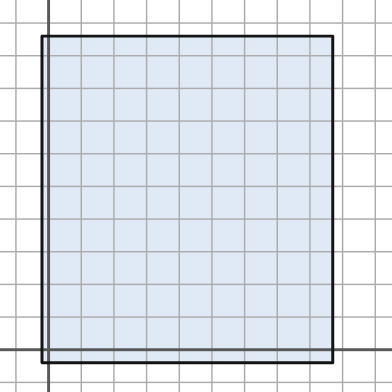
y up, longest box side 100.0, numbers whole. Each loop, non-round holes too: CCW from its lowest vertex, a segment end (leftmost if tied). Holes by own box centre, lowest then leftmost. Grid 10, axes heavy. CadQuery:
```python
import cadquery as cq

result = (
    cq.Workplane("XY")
    .moveTo(-2.0, -4.0)
    .lineTo(87.0, -4.0)
    .lineTo(87.0, 96.0)
    .lineTo(-2.0, 96.0)
    .close()
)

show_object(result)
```